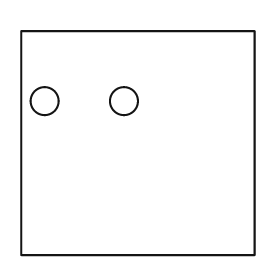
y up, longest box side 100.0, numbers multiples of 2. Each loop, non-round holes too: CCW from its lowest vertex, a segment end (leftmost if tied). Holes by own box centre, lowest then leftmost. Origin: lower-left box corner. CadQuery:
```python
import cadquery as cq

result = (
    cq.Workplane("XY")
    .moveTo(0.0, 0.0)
    .lineTo(100.0, 0.0)
    .lineTo(100.0, 96.0)
    .lineTo(0.0, 96.0)
    .close()
    .moveTo(10.0, 66.0)
    .circle(6.0)
    .moveTo(44.0, 66.0)
    .circle(6.0)
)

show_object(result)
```